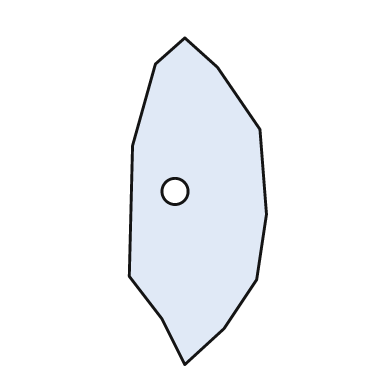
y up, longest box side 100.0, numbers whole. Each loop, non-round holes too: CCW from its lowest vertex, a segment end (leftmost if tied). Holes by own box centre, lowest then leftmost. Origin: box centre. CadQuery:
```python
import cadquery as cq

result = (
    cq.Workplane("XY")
    .moveTo(-4.0, -50.0)
    .lineTo(8.0, -39.0)
    .lineTo(18.0, -24.0)
    .lineTo(21.0, -4.0)
    .lineTo(19.0, 22.0)
    .lineTo(6.0, 41.0)
    .lineTo(-4.0, 50.0)
    .lineTo(-13.0, 42.0)
    .lineTo(-20.0, 17.0)
    .lineTo(-21.0, -23.0)
    .lineTo(-11.0, -36.0)
    .close()
    .moveTo(-7.0, 3.0)
    .circle(4.0)
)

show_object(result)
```